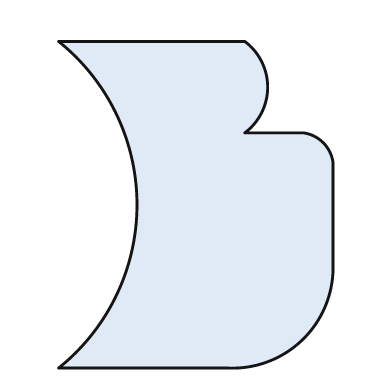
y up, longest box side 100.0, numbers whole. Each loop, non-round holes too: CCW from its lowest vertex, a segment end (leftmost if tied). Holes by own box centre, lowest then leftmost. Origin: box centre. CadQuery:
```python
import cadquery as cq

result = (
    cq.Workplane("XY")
    .moveTo(-42.0, -50.0)
    .lineTo(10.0, -50.0)
    .threePointArc((33.0, -41.0), (42.0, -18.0))
    .lineTo(42.0, 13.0)
    .threePointArc((39.0, 19.0), (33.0, 22.0))
    .lineTo(15.0, 22.0)
    .threePointArc((22.0, 36.0), (15.0, 50.0))
    .lineTo(-42.0, 50.0)
    .threePointArc((-18.0, 0.0), (-42.0, -50.0))
    .close()
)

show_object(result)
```